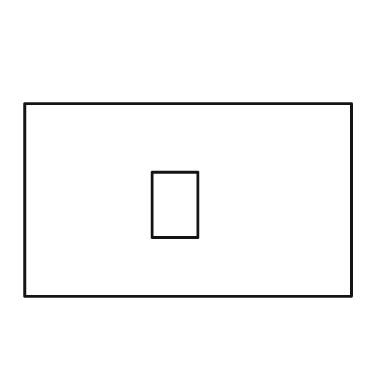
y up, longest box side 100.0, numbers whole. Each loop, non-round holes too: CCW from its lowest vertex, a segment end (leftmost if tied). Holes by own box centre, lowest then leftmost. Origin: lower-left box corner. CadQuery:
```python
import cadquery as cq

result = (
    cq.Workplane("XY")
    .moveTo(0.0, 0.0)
    .lineTo(100.0, 0.0)
    .lineTo(100.0, 59.0)
    .lineTo(0.0, 59.0)
    .close()
    .moveTo(39.0, 18.0)
    .lineTo(53.0, 18.0)
    .lineTo(53.0, 38.0)
    .lineTo(39.0, 38.0)
    .close()
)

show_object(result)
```